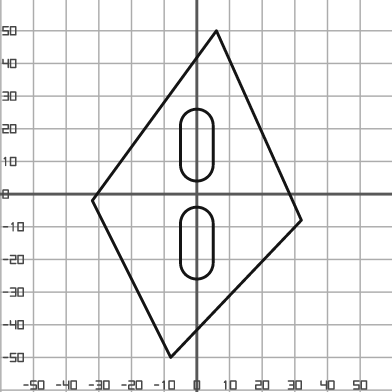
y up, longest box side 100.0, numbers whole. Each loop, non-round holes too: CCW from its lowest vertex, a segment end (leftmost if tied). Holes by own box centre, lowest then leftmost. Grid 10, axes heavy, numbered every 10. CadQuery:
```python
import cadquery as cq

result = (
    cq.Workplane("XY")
    .moveTo(-8.0, -50.0)
    .lineTo(32.0, -8.0)
    .lineTo(6.0, 50.0)
    .lineTo(-32.0, -2.0)
    .close()
    .moveTo(-5.0, -21.0)
    .threePointArc((0.0, -26.0), (5.0, -21.0))
    .lineTo(5.0, -9.0)
    .threePointArc((0.0, -4.0), (-5.0, -9.0))
    .close()
    .moveTo(-5.0, 9.0)
    .threePointArc((0.0, 4.0), (5.0, 9.0))
    .lineTo(5.0, 21.0)
    .threePointArc((0.0, 26.0), (-5.0, 21.0))
    .close()
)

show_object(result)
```